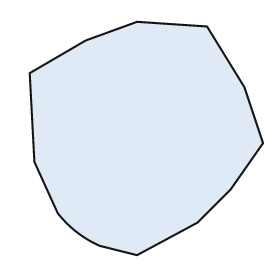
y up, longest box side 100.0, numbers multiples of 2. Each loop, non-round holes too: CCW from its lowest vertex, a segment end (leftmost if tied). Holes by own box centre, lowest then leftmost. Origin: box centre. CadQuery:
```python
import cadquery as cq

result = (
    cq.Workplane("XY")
    .moveTo(-4.0, -50.0)
    .lineTo(22.0, -36.0)
    .lineTo(36.0, -22.0)
    .lineTo(50.0, -2.0)
    .lineTo(42.0, 22.0)
    .lineTo(26.0, 48.0)
    .lineTo(-4.0, 50.0)
    .lineTo(-26.0, 42.0)
    .lineTo(-50.0, 28.0)
    .lineTo(-48.0, -10.0)
    .lineTo(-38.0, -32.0)
    .threePointArc((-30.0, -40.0), (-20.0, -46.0))
    .close()
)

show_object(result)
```